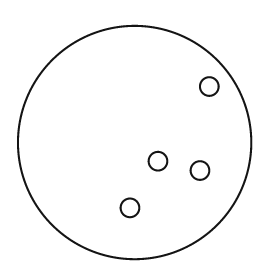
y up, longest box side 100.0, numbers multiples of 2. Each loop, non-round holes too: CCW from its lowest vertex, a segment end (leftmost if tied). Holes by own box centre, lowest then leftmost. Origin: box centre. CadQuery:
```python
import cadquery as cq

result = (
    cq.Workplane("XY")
    .moveTo(0.0, 0.0)
    .circle(50.0)
    .moveTo(-2.0, -28.0)
    .circle(4.0)
    .moveTo(28.0, -12.0)
    .circle(4.0)
    .moveTo(10.0, -8.0)
    .circle(4.0)
    .moveTo(32.0, 24.0)
    .circle(4.0)
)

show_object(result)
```